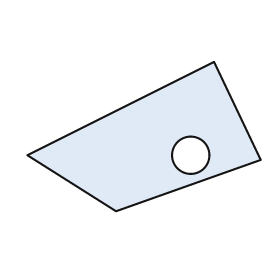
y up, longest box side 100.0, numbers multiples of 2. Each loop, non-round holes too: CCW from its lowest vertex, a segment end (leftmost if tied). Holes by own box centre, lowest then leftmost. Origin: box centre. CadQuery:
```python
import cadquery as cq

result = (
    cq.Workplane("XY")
    .moveTo(-12.0, -32.0)
    .lineTo(50.0, -10.0)
    .lineTo(30.0, 32.0)
    .lineTo(-50.0, -8.0)
    .close()
    .moveTo(20.0, -8.0)
    .circle(8.0)
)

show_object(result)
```